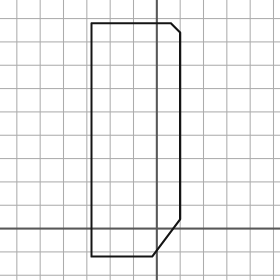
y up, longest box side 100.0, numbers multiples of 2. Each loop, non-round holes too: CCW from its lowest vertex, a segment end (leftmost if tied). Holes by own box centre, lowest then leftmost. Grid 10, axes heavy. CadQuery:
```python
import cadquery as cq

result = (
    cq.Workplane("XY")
    .moveTo(-28.0, -12.0)
    .lineTo(-2.0, -12.0)
    .lineTo(10.0, 4.0)
    .lineTo(10.0, 84.0)
    .lineTo(6.0, 88.0)
    .lineTo(-28.0, 88.0)
    .close()
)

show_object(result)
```